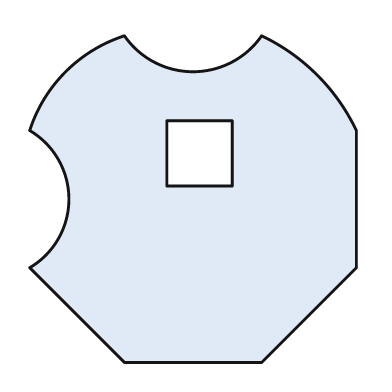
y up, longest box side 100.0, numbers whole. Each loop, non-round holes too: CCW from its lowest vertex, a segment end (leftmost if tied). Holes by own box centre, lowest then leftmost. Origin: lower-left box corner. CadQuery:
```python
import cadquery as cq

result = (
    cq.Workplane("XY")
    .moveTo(29.0, 0.0)
    .lineTo(71.0, 0.0)
    .lineTo(100.0, 29.0)
    .lineTo(100.0, 71.0)
    .threePointArc((88.0, 88.0), (71.0, 100.0))
    .threePointArc((50.0, 89.0), (29.0, 100.0))
    .threePointArc((11.0, 89.0), (0.0, 71.0))
    .threePointArc((12.0, 50.0), (0.0, 29.0))
    .close()
    .moveTo(42.0, 54.0)
    .lineTo(62.0, 54.0)
    .lineTo(62.0, 74.0)
    .lineTo(42.0, 74.0)
    .close()
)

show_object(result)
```